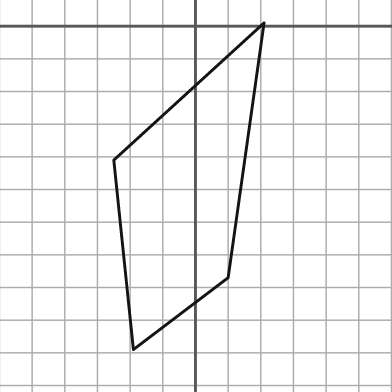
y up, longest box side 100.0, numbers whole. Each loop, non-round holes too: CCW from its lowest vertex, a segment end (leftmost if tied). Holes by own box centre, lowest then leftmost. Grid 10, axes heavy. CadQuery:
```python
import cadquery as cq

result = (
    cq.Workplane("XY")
    .moveTo(-19.0, -99.0)
    .lineTo(10.0, -77.0)
    .lineTo(21.0, 1.0)
    .lineTo(-25.0, -41.0)
    .close()
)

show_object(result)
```